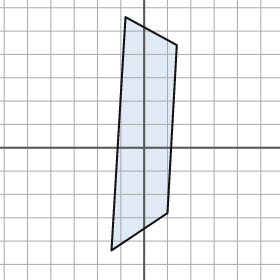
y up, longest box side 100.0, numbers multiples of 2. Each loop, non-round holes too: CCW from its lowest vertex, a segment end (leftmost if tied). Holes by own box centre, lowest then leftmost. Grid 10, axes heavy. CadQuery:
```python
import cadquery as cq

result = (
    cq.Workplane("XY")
    .moveTo(-14.0, -44.0)
    .lineTo(10.0, -28.0)
    .lineTo(14.0, 44.0)
    .lineTo(-8.0, 56.0)
    .close()
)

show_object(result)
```